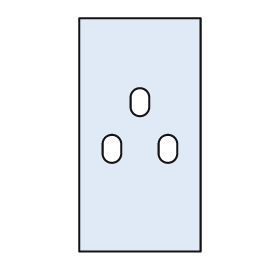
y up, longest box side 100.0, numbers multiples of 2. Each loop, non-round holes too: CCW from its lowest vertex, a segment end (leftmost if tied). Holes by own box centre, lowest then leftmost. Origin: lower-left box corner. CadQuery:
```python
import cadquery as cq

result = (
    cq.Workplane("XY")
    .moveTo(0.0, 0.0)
    .lineTo(52.0, 0.0)
    .lineTo(52.0, 100.0)
    .lineTo(0.0, 100.0)
    .close()
    .moveTo(10.0, 42.0)
    .threePointArc((14.0, 38.0), (18.0, 42.0))
    .lineTo(18.0, 46.0)
    .threePointArc((14.0, 50.0), (10.0, 46.0))
    .close()
    .moveTo(34.0, 42.0)
    .threePointArc((38.0, 38.0), (42.0, 42.0))
    .lineTo(42.0, 46.0)
    .threePointArc((38.0, 50.0), (34.0, 46.0))
    .close()
    .moveTo(22.0, 62.0)
    .threePointArc((26.0, 58.0), (30.0, 62.0))
    .lineTo(30.0, 66.0)
    .threePointArc((26.0, 70.0), (22.0, 66.0))
    .close()
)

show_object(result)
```